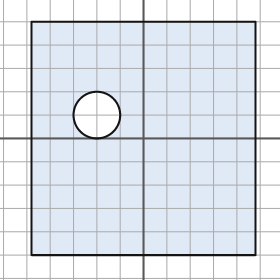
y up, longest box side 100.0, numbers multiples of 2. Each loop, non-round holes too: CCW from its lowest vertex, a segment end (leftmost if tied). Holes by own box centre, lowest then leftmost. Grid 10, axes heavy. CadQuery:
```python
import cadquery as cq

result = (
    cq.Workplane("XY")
    .moveTo(-48.0, -50.0)
    .lineTo(48.0, -50.0)
    .lineTo(48.0, 50.0)
    .lineTo(-48.0, 50.0)
    .close()
    .moveTo(-20.0, 10.0)
    .circle(10.0)
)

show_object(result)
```